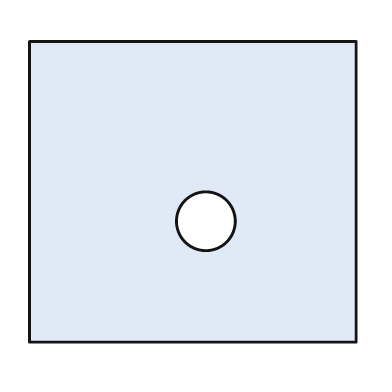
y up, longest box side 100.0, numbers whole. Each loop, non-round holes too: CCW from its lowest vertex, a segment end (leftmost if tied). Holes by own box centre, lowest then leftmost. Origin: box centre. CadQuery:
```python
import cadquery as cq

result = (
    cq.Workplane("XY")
    .moveTo(-50.0, -46.0)
    .lineTo(50.0, -46.0)
    .lineTo(50.0, 46.0)
    .lineTo(-50.0, 46.0)
    .close()
    .moveTo(4.0, -9.0)
    .circle(9.0)
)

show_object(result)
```